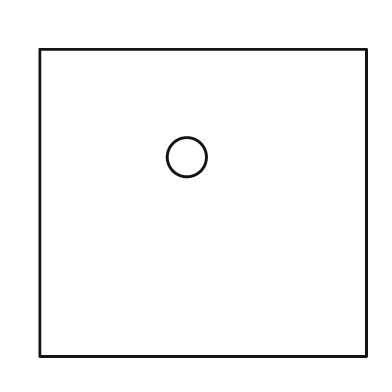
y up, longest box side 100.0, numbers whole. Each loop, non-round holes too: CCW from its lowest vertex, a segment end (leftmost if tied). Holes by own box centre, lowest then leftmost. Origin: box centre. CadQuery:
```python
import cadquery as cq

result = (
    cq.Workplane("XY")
    .moveTo(-50.0, -47.0)
    .lineTo(50.0, -47.0)
    .lineTo(50.0, 47.0)
    .lineTo(-50.0, 47.0)
    .close()
    .moveTo(-5.0, 14.0)
    .circle(6.0)
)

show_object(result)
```